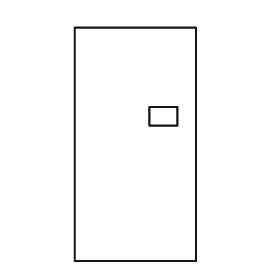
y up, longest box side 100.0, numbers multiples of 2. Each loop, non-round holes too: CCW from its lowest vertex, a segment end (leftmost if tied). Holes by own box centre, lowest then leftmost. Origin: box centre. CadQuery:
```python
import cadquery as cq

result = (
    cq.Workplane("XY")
    .moveTo(-26.0, -50.0)
    .lineTo(26.0, -50.0)
    .lineTo(26.0, 50.0)
    .lineTo(-26.0, 50.0)
    .close()
    .moveTo(6.0, 8.0)
    .lineTo(18.0, 8.0)
    .lineTo(18.0, 16.0)
    .lineTo(6.0, 16.0)
    .close()
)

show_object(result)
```